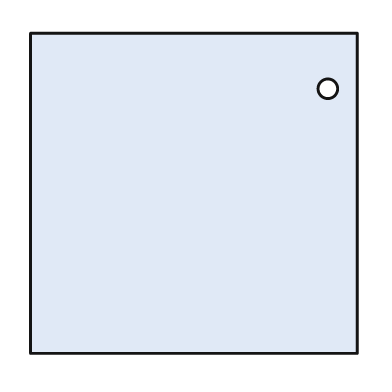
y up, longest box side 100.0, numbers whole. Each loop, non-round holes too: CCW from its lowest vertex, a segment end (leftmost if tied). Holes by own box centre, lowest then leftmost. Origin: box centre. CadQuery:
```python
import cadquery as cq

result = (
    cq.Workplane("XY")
    .moveTo(-50.0, -49.0)
    .lineTo(50.0, -49.0)
    .lineTo(50.0, 49.0)
    .lineTo(-50.0, 49.0)
    .close()
    .moveTo(41.0, 32.0)
    .circle(3.0)
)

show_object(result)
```